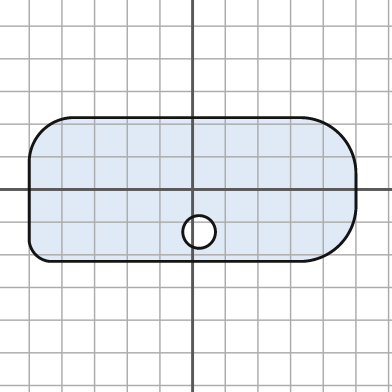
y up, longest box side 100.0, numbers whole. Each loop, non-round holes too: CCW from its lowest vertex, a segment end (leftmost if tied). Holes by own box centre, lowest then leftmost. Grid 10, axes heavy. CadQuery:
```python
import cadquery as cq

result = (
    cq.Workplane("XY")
    .moveTo(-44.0, -22.0)
    .lineTo(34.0, -22.0)
    .threePointArc((45.0, -17.0), (50.0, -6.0))
    .lineTo(50.0, 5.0)
    .threePointArc((45.0, 17.0), (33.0, 22.0))
    .lineTo(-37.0, 22.0)
    .threePointArc((-46.0, 18.0), (-50.0, 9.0))
    .lineTo(-50.0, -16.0)
    .threePointArc((-48.0, -20.0), (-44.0, -22.0))
    .close()
    .moveTo(2.0, -13.0)
    .circle(5.0)
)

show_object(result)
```